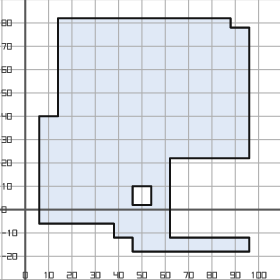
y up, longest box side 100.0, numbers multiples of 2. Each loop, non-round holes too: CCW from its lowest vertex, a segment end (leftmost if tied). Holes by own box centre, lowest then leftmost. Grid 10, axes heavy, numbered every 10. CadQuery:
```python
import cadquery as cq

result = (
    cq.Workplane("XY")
    .moveTo(46.0, -18.0)
    .lineTo(96.0, -18.0)
    .lineTo(96.0, -12.0)
    .lineTo(62.0, -12.0)
    .lineTo(62.0, 22.0)
    .lineTo(96.0, 22.0)
    .lineTo(96.0, 78.0)
    .lineTo(88.0, 78.0)
    .lineTo(88.0, 82.0)
    .lineTo(14.0, 82.0)
    .lineTo(14.0, 40.0)
    .lineTo(6.0, 40.0)
    .lineTo(6.0, -6.0)
    .lineTo(38.0, -6.0)
    .lineTo(38.0, -12.0)
    .lineTo(46.0, -12.0)
    .close()
    .moveTo(46.0, 2.0)
    .lineTo(54.0, 2.0)
    .lineTo(54.0, 10.0)
    .lineTo(46.0, 10.0)
    .close()
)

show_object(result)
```